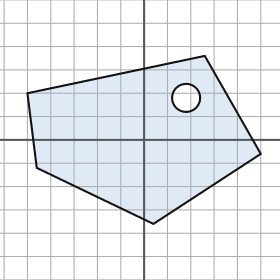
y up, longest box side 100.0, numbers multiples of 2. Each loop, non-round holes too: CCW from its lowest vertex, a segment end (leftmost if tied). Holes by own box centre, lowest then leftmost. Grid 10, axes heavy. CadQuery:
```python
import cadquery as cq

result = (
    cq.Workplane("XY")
    .moveTo(4.0, -36.0)
    .lineTo(50.0, -6.0)
    .lineTo(26.0, 36.0)
    .lineTo(-50.0, 20.0)
    .lineTo(-46.0, -12.0)
    .close()
    .moveTo(18.0, 18.0)
    .circle(6.0)
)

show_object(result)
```